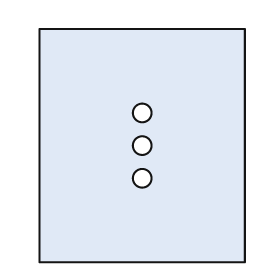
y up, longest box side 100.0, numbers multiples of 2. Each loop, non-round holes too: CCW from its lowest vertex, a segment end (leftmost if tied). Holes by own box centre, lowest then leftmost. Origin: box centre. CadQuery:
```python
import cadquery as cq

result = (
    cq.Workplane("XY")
    .moveTo(-44.0, -50.0)
    .lineTo(44.0, -50.0)
    .lineTo(44.0, 50.0)
    .lineTo(-44.0, 50.0)
    .close()
    .moveTo(0.0, -14.0)
    .circle(4.0)
    .moveTo(0.0, 0.0)
    .circle(4.0)
    .moveTo(0.0, 14.0)
    .circle(4.0)
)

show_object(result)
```